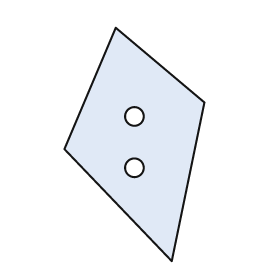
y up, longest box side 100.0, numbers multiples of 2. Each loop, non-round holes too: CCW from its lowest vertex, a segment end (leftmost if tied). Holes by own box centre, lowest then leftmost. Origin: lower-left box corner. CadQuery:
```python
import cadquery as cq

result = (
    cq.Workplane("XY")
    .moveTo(46.0, 0.0)
    .lineTo(60.0, 68.0)
    .lineTo(22.0, 100.0)
    .lineTo(0.0, 48.0)
    .close()
    .moveTo(30.0, 40.0)
    .circle(4.0)
    .moveTo(30.0, 62.0)
    .circle(4.0)
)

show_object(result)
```